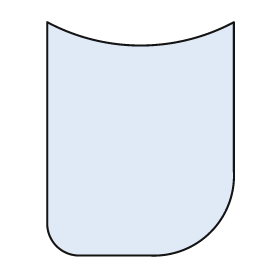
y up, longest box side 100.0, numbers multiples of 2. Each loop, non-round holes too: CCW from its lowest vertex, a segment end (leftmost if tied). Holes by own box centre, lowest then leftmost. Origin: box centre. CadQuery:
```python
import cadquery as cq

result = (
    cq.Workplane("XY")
    .moveTo(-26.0, -50.0)
    .lineTo(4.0, -50.0)
    .threePointArc((30.0, -40.0), (40.0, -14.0))
    .lineTo(40.0, 50.0)
    .threePointArc((0.0, 40.0), (-40.0, 50.0))
    .lineTo(-40.0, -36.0)
    .threePointArc((-36.0, -46.0), (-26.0, -50.0))
    .close()
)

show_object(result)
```